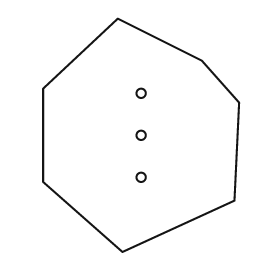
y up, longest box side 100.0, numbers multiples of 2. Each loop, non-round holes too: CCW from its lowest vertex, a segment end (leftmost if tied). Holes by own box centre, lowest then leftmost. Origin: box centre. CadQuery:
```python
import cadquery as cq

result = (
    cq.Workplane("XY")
    .moveTo(-8.0, -50.0)
    .lineTo(40.0, -28.0)
    .lineTo(42.0, 14.0)
    .lineTo(26.0, 32.0)
    .lineTo(-10.0, 50.0)
    .lineTo(-42.0, 20.0)
    .lineTo(-42.0, -20.0)
    .close()
    .moveTo(0.0, -18.0)
    .circle(2.0)
    .moveTo(0.0, 0.0)
    .circle(2.0)
    .moveTo(0.0, 18.0)
    .circle(2.0)
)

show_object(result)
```